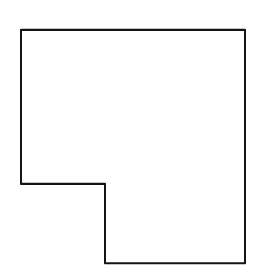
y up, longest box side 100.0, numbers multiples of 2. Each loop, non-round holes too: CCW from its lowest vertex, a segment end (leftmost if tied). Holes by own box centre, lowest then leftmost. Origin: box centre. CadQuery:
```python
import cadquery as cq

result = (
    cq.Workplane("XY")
    .moveTo(-12.0, -50.0)
    .lineTo(48.0, -50.0)
    .lineTo(48.0, 50.0)
    .lineTo(-48.0, 50.0)
    .lineTo(-48.0, -16.0)
    .lineTo(-12.0, -16.0)
    .close()
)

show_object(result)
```